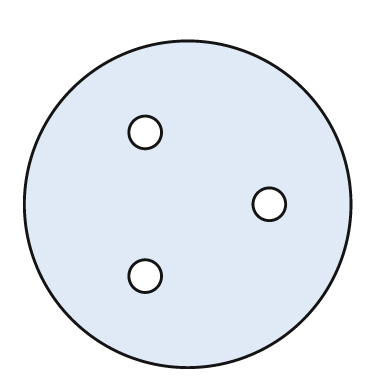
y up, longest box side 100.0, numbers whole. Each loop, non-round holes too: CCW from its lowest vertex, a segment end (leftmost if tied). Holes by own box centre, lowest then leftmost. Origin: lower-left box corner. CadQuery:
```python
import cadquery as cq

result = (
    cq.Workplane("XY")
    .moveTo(50.0, 50.0)
    .circle(50.0)
    .moveTo(37.0, 28.0)
    .circle(5.0)
    .moveTo(75.0, 50.0)
    .circle(5.0)
    .moveTo(37.0, 72.0)
    .circle(5.0)
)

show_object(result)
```